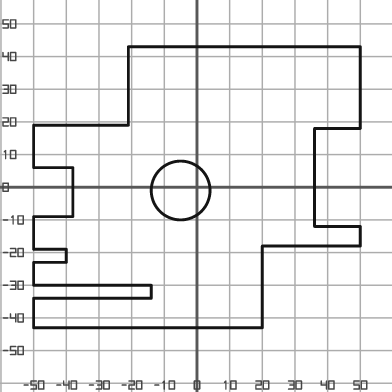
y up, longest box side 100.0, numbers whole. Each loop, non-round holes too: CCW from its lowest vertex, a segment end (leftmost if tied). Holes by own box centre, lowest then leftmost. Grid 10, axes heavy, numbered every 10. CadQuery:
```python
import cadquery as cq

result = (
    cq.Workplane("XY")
    .moveTo(-50.0, -43.0)
    .lineTo(20.0, -43.0)
    .lineTo(20.0, -18.0)
    .lineTo(50.0, -18.0)
    .lineTo(50.0, -12.0)
    .lineTo(36.0, -12.0)
    .lineTo(36.0, 18.0)
    .lineTo(50.0, 18.0)
    .lineTo(50.0, 43.0)
    .lineTo(-21.0, 43.0)
    .lineTo(-21.0, 19.0)
    .lineTo(-50.0, 19.0)
    .lineTo(-50.0, 6.0)
    .lineTo(-38.0, 6.0)
    .lineTo(-38.0, -9.0)
    .lineTo(-50.0, -9.0)
    .lineTo(-50.0, -19.0)
    .lineTo(-40.0, -19.0)
    .lineTo(-40.0, -23.0)
    .lineTo(-50.0, -23.0)
    .lineTo(-50.0, -30.0)
    .lineTo(-14.0, -30.0)
    .lineTo(-14.0, -34.0)
    .lineTo(-50.0, -34.0)
    .close()
    .moveTo(-5.0, -1.0)
    .circle(9.0)
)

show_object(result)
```